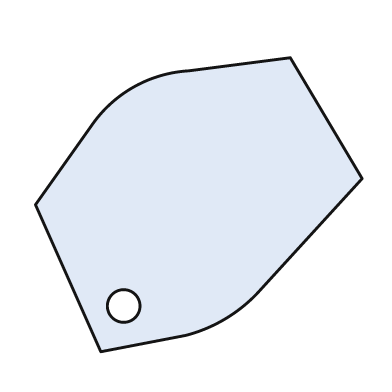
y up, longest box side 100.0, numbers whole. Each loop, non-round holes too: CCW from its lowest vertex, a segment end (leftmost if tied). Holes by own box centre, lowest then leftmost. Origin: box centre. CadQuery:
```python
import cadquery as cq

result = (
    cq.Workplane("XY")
    .moveTo(-30.0, -45.0)
    .lineTo(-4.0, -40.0)
    .threePointArc((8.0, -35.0), (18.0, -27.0))
    .lineTo(50.0, 8.0)
    .lineTo(28.0, 45.0)
    .lineTo(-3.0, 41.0)
    .threePointArc((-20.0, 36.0), (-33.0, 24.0))
    .lineTo(-50.0, 0.0)
    .close()
    .moveTo(-23.0, -31.0)
    .circle(5.0)
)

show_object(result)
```